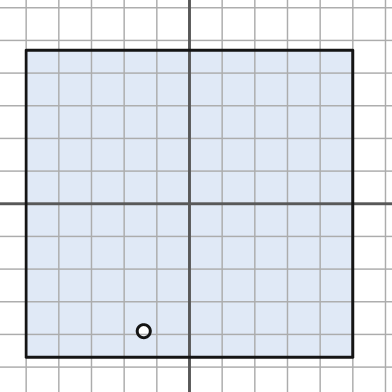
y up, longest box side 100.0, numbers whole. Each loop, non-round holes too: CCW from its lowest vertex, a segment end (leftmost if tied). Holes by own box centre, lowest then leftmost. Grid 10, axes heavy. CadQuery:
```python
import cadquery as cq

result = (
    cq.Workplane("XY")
    .moveTo(-50.0, -47.0)
    .lineTo(50.0, -47.0)
    .lineTo(50.0, 47.0)
    .lineTo(-50.0, 47.0)
    .close()
    .moveTo(-14.0, -39.0)
    .circle(2.0)
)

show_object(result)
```